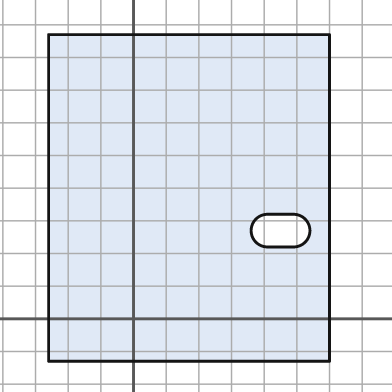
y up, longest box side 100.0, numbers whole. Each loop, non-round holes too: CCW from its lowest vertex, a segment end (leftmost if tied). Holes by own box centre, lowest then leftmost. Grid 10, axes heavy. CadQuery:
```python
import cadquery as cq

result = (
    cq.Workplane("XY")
    .moveTo(-26.0, -13.0)
    .lineTo(60.0, -13.0)
    .lineTo(60.0, 87.0)
    .lineTo(-26.0, 87.0)
    .close()
    .moveTo(41.0, 22.0)
    .lineTo(49.0, 22.0)
    .threePointArc((54.0, 27.0), (49.0, 32.0))
    .lineTo(41.0, 32.0)
    .threePointArc((36.0, 27.0), (41.0, 22.0))
    .close()
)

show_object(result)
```